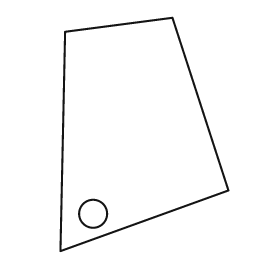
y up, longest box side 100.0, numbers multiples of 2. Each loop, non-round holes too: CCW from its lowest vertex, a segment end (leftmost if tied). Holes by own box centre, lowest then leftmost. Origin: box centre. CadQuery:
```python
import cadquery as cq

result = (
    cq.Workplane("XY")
    .moveTo(-36.0, -50.0)
    .lineTo(36.0, -24.0)
    .lineTo(12.0, 50.0)
    .lineTo(-34.0, 44.0)
    .close()
    .moveTo(-22.0, -34.0)
    .circle(6.0)
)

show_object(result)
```